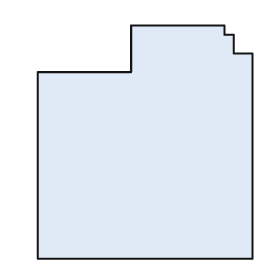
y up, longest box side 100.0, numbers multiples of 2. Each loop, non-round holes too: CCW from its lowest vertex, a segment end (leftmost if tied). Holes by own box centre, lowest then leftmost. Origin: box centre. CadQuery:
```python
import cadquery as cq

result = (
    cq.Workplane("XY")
    .moveTo(-46.0, -50.0)
    .lineTo(46.0, -50.0)
    .lineTo(46.0, 38.0)
    .lineTo(38.0, 38.0)
    .lineTo(38.0, 46.0)
    .lineTo(34.0, 46.0)
    .lineTo(34.0, 50.0)
    .lineTo(-6.0, 50.0)
    .lineTo(-6.0, 30.0)
    .lineTo(-46.0, 30.0)
    .close()
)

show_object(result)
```